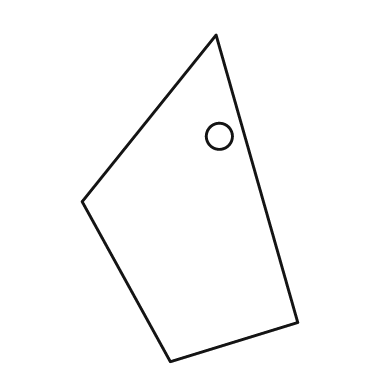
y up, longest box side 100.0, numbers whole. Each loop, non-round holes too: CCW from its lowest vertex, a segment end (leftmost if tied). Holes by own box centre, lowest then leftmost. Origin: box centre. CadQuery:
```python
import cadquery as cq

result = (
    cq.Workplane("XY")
    .moveTo(-6.0, -50.0)
    .lineTo(33.0, -38.0)
    .lineTo(8.0, 50.0)
    .lineTo(-33.0, -1.0)
    .close()
    .moveTo(9.0, 19.0)
    .circle(4.0)
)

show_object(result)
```